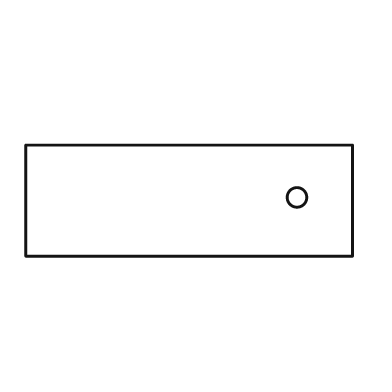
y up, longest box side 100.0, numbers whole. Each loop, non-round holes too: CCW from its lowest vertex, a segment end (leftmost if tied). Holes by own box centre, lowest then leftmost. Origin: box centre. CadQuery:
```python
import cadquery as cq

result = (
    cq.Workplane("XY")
    .moveTo(-50.0, -17.0)
    .lineTo(50.0, -17.0)
    .lineTo(50.0, 17.0)
    .lineTo(-50.0, 17.0)
    .close()
    .moveTo(33.0, 1.0)
    .circle(3.0)
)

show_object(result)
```